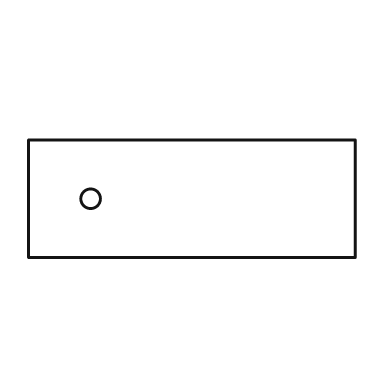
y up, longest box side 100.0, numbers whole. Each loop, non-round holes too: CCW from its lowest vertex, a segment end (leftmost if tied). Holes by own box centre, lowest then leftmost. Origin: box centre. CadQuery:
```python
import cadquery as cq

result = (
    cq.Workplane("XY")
    .moveTo(-50.0, -18.0)
    .lineTo(50.0, -18.0)
    .lineTo(50.0, 18.0)
    .lineTo(-50.0, 18.0)
    .close()
    .moveTo(-31.0, 0.0)
    .circle(3.0)
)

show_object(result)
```